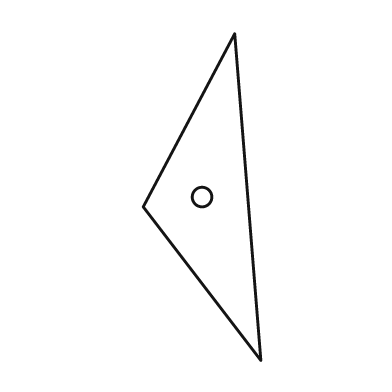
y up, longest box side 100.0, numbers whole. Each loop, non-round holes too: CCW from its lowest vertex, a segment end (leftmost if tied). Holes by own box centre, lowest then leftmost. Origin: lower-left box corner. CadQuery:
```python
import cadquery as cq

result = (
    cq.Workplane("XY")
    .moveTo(36.0, 0.0)
    .lineTo(28.0, 100.0)
    .lineTo(0.0, 47.0)
    .close()
    .moveTo(18.0, 50.0)
    .circle(3.0)
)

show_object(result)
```